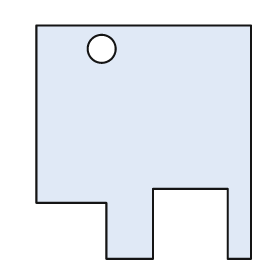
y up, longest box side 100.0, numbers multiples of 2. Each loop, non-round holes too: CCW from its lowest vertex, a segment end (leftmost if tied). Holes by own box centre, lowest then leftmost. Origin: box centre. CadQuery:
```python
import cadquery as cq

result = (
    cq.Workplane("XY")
    .moveTo(-16.0, -50.0)
    .lineTo(4.0, -50.0)
    .lineTo(4.0, -20.0)
    .lineTo(36.0, -20.0)
    .lineTo(36.0, -50.0)
    .lineTo(46.0, -50.0)
    .lineTo(46.0, 50.0)
    .lineTo(-46.0, 50.0)
    .lineTo(-46.0, -26.0)
    .lineTo(-16.0, -26.0)
    .close()
    .moveTo(-18.0, 40.0)
    .circle(6.0)
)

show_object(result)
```